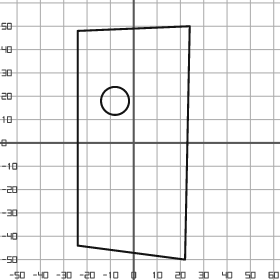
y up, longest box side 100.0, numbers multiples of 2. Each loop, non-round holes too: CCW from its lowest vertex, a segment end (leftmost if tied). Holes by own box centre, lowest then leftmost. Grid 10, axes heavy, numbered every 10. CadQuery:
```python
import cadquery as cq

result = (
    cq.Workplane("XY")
    .moveTo(22.0, -50.0)
    .lineTo(24.0, 50.0)
    .lineTo(-24.0, 48.0)
    .lineTo(-24.0, -44.0)
    .close()
    .moveTo(-8.0, 18.0)
    .circle(6.0)
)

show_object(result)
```